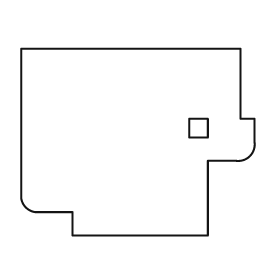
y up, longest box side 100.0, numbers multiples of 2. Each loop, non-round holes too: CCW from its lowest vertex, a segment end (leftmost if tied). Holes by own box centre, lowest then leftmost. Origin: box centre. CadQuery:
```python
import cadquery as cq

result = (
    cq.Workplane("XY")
    .moveTo(-28.0, -40.0)
    .lineTo(30.0, -40.0)
    .lineTo(30.0, -8.0)
    .lineTo(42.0, -8.0)
    .threePointArc((48.0, -6.0), (50.0, 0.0))
    .lineTo(50.0, 10.0)
    .lineTo(44.0, 10.0)
    .lineTo(44.0, 40.0)
    .lineTo(-50.0, 40.0)
    .lineTo(-50.0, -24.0)
    .threePointArc((-48.0, -28.0), (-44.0, -30.0))
    .lineTo(-28.0, -30.0)
    .close()
    .moveTo(22.0, 2.0)
    .lineTo(30.0, 2.0)
    .lineTo(30.0, 10.0)
    .lineTo(22.0, 10.0)
    .close()
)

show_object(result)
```